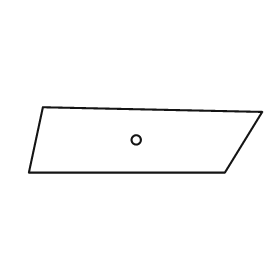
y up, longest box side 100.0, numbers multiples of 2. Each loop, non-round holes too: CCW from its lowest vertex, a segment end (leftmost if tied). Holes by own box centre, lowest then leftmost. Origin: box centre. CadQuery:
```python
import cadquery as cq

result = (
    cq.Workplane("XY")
    .moveTo(-50.0, -14.0)
    .lineTo(34.0, -14.0)
    .lineTo(50.0, 12.0)
    .lineTo(-44.0, 14.0)
    .close()
    .moveTo(-4.0, 0.0)
    .circle(2.0)
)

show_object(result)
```